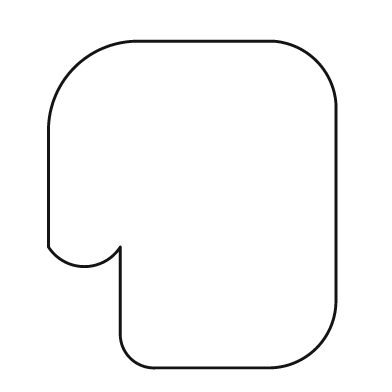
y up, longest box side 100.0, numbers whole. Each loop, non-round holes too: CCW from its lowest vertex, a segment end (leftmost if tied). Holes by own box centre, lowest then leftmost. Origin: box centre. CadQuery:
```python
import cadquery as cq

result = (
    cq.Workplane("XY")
    .moveTo(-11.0, -50.0)
    .lineTo(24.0, -50.0)
    .threePointArc((38.0, -44.0), (44.0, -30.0))
    .lineTo(44.0, 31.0)
    .threePointArc((38.0, 44.0), (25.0, 50.0))
    .lineTo(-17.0, 50.0)
    .threePointArc((-36.0, 42.0), (-44.0, 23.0))
    .lineTo(-44.0, -13.0)
    .threePointArc((-33.0, -19.0), (-22.0, -13.0))
    .lineTo(-22.0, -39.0)
    .threePointArc((-19.0, -47.0), (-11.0, -50.0))
    .close()
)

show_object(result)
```